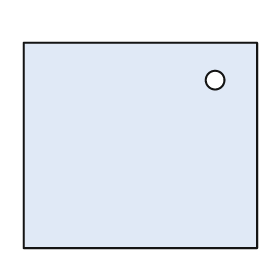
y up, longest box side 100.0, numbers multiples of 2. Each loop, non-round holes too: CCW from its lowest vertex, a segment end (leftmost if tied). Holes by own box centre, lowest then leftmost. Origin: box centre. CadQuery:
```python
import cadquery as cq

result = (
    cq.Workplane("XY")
    .moveTo(-50.0, -44.0)
    .lineTo(50.0, -44.0)
    .lineTo(50.0, 44.0)
    .lineTo(-50.0, 44.0)
    .close()
    .moveTo(32.0, 28.0)
    .circle(4.0)
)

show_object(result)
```